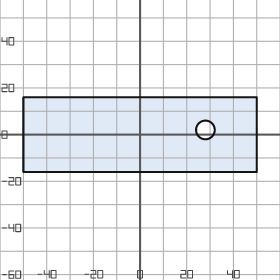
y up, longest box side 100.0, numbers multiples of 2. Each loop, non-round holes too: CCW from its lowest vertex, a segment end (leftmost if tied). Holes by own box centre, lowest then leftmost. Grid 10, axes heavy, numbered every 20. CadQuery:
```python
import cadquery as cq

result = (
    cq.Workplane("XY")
    .moveTo(-50.0, -16.0)
    .lineTo(50.0, -16.0)
    .lineTo(50.0, 16.0)
    .lineTo(-50.0, 16.0)
    .close()
    .moveTo(28.0, 2.0)
    .circle(4.0)
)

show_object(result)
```